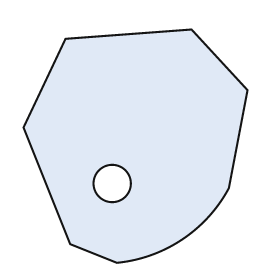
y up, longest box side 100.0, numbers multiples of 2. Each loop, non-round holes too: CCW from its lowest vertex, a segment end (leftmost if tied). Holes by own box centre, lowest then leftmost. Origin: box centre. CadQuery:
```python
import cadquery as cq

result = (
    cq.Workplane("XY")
    .moveTo(-8.0, -50.0)
    .threePointArc((20.0, -40.0), (40.0, -18.0))
    .lineTo(48.0, 24.0)
    .lineTo(24.0, 50.0)
    .lineTo(-30.0, 46.0)
    .lineTo(-48.0, 8.0)
    .lineTo(-28.0, -42.0)
    .close()
    .moveTo(-10.0, -16.0)
    .circle(8.0)
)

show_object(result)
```